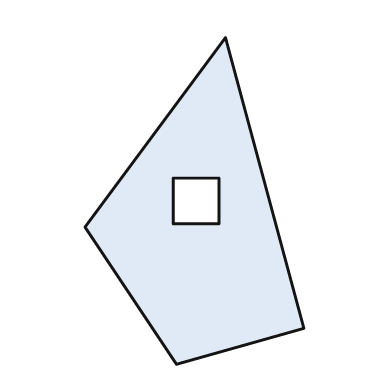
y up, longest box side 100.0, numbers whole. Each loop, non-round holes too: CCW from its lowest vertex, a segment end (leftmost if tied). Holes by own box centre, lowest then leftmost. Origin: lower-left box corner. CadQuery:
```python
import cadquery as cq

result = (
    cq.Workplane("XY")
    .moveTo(28.0, 0.0)
    .lineTo(67.0, 11.0)
    .lineTo(43.0, 100.0)
    .lineTo(0.0, 42.0)
    .close()
    .moveTo(27.0, 43.0)
    .lineTo(41.0, 43.0)
    .lineTo(41.0, 57.0)
    .lineTo(27.0, 57.0)
    .close()
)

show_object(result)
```